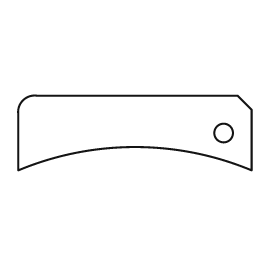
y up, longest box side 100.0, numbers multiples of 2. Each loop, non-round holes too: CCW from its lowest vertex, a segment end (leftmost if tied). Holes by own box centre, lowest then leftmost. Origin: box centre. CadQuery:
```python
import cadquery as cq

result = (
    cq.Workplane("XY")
    .moveTo(-50.0, -16.0)
    .threePointArc((0.0, -6.0), (50.0, -16.0))
    .lineTo(50.0, 10.0)
    .lineTo(44.0, 16.0)
    .lineTo(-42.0, 16.0)
    .threePointArc((-48.0, 14.0), (-50.0, 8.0))
    .close()
    .moveTo(38.0, 0.0)
    .circle(4.0)
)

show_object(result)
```